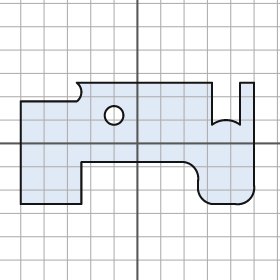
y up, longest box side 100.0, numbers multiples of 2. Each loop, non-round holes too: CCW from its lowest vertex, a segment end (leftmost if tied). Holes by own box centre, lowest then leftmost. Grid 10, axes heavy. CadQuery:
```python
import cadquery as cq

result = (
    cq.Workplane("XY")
    .moveTo(-50.0, -26.0)
    .lineTo(-24.0, -26.0)
    .lineTo(-24.0, -8.0)
    .lineTo(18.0, -8.0)
    .threePointArc((24.0, -10.0), (26.0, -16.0))
    .lineTo(26.0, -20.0)
    .threePointArc((28.0, -24.0), (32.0, -26.0))
    .lineTo(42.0, -26.0)
    .threePointArc((48.0, -24.0), (50.0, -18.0))
    .lineTo(50.0, 26.0)
    .lineTo(44.0, 26.0)
    .lineTo(44.0, 8.0)
    .threePointArc((38.0, 10.0), (32.0, 8.0))
    .lineTo(32.0, 26.0)
    .lineTo(-26.0, 26.0)
    .threePointArc((-24.0, 22.0), (-26.0, 18.0))
    .lineTo(-50.0, 18.0)
    .close()
    .moveTo(-10.0, 12.0)
    .circle(4.0)
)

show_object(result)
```